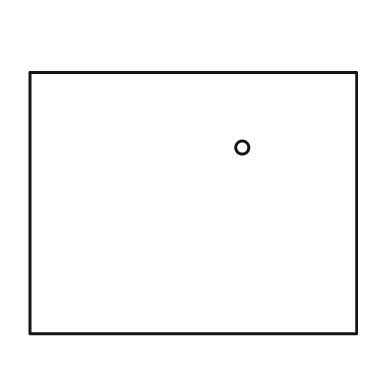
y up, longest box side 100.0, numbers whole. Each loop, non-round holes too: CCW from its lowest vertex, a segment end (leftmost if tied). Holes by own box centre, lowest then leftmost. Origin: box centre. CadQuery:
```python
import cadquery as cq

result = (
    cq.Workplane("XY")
    .moveTo(-50.0, -40.0)
    .lineTo(50.0, -40.0)
    .lineTo(50.0, 40.0)
    .lineTo(-50.0, 40.0)
    .close()
    .moveTo(15.0, 17.0)
    .circle(2.0)
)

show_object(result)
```